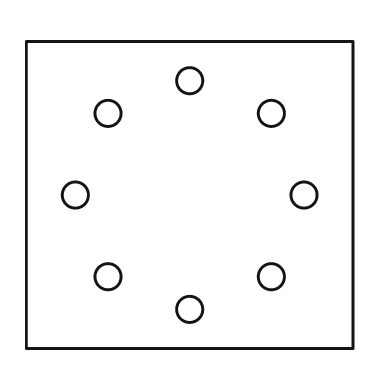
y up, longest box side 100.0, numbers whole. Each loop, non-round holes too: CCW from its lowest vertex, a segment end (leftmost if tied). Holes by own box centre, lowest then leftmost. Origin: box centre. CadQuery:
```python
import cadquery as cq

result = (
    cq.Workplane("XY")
    .moveTo(-50.0, -47.0)
    .lineTo(50.0, -47.0)
    .lineTo(50.0, 47.0)
    .lineTo(-50.0, 47.0)
    .close()
    .moveTo(0.0, -35.0)
    .circle(4.0)
    .moveTo(-25.0, -25.0)
    .circle(4.0)
    .moveTo(25.0, -25.0)
    .circle(4.0)
    .moveTo(-35.0, 0.0)
    .circle(4.0)
    .moveTo(35.0, 0.0)
    .circle(4.0)
    .moveTo(-25.0, 25.0)
    .circle(4.0)
    .moveTo(25.0, 25.0)
    .circle(4.0)
    .moveTo(0.0, 35.0)
    .circle(4.0)
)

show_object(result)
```